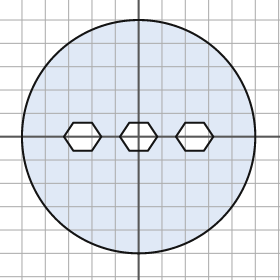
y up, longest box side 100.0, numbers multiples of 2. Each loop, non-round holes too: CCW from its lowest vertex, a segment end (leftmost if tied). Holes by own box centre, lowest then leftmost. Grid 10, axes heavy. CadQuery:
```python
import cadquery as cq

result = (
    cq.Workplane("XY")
    .moveTo(0.0, 0.0)
    .circle(50.0)
    .moveTo(-28.0, -6.0)
    .lineTo(-20.0, -6.0)
    .lineTo(-16.0, 0.0)
    .lineTo(-20.0, 6.0)
    .lineTo(-28.0, 6.0)
    .lineTo(-32.0, 0.0)
    .close()
    .moveTo(-4.0, -6.0)
    .lineTo(4.0, -6.0)
    .lineTo(8.0, 0.0)
    .lineTo(4.0, 6.0)
    .lineTo(-4.0, 6.0)
    .lineTo(-8.0, 0.0)
    .close()
    .moveTo(20.0, -6.0)
    .lineTo(28.0, -6.0)
    .lineTo(32.0, 0.0)
    .lineTo(28.0, 6.0)
    .lineTo(20.0, 6.0)
    .lineTo(16.0, 0.0)
    .close()
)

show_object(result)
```